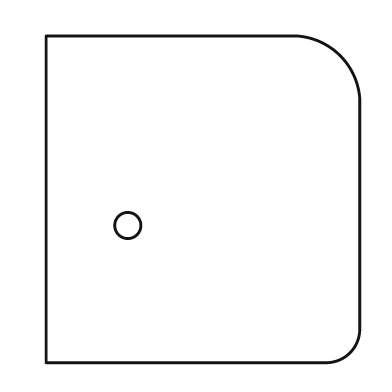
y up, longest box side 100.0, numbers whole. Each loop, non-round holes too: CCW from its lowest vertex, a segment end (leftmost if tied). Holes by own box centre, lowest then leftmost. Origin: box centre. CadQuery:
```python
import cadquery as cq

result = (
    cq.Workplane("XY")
    .moveTo(-48.0, -50.0)
    .lineTo(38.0, -50.0)
    .threePointArc((45.0, -47.0), (48.0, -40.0))
    .lineTo(48.0, 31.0)
    .threePointArc((42.0, 44.0), (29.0, 50.0))
    .lineTo(-48.0, 50.0)
    .close()
    .moveTo(-23.0, -8.0)
    .circle(4.0)
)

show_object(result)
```